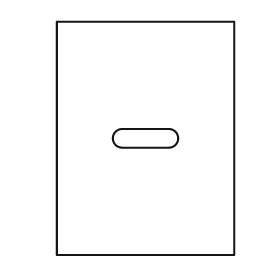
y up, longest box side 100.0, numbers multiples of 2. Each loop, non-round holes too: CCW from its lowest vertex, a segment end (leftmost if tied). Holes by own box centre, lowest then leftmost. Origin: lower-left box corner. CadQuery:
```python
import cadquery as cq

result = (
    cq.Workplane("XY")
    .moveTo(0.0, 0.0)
    .lineTo(76.0, 0.0)
    .lineTo(76.0, 100.0)
    .lineTo(0.0, 100.0)
    .close()
    .moveTo(28.0, 46.0)
    .lineTo(48.0, 46.0)
    .threePointArc((52.0, 50.0), (48.0, 54.0))
    .lineTo(28.0, 54.0)
    .threePointArc((24.0, 50.0), (28.0, 46.0))
    .close()
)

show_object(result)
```